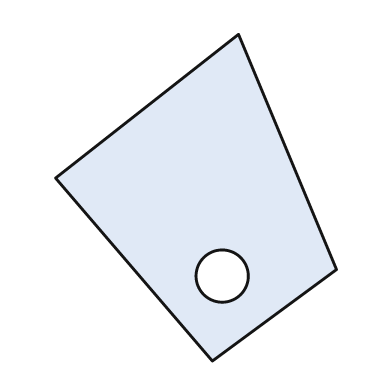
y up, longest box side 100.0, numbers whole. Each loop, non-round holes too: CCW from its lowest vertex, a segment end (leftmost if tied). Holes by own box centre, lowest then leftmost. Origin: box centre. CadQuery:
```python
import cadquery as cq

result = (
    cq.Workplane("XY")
    .moveTo(5.0, -50.0)
    .lineTo(43.0, -22.0)
    .lineTo(13.0, 50.0)
    .lineTo(-43.0, 6.0)
    .close()
    .moveTo(8.0, -24.0)
    .circle(8.0)
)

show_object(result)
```